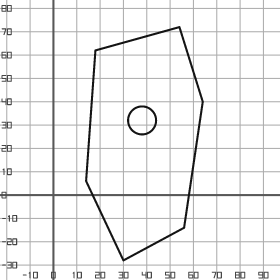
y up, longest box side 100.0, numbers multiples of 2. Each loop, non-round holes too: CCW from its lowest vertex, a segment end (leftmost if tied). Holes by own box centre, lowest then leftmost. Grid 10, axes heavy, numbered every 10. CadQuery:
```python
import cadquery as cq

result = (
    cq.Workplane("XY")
    .moveTo(30.0, -28.0)
    .lineTo(56.0, -14.0)
    .lineTo(64.0, 40.0)
    .lineTo(54.0, 72.0)
    .lineTo(18.0, 62.0)
    .lineTo(14.0, 6.0)
    .close()
    .moveTo(38.0, 32.0)
    .circle(6.0)
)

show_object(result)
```